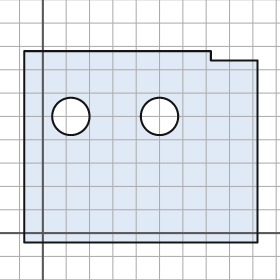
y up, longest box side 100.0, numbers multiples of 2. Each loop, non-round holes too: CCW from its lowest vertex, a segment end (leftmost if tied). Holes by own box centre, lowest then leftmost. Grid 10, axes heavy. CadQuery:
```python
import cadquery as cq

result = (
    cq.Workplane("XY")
    .moveTo(-8.0, -4.0)
    .lineTo(92.0, -4.0)
    .lineTo(92.0, 74.0)
    .lineTo(72.0, 74.0)
    .lineTo(72.0, 78.0)
    .lineTo(-8.0, 78.0)
    .close()
    .moveTo(12.0, 50.0)
    .circle(8.0)
    .moveTo(50.0, 50.0)
    .circle(8.0)
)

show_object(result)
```